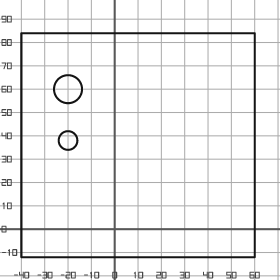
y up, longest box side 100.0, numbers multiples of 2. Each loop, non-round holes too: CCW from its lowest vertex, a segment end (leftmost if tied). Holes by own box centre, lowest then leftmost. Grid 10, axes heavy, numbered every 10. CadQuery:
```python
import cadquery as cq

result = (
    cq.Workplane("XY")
    .moveTo(-40.0, -12.0)
    .lineTo(60.0, -12.0)
    .lineTo(60.0, 84.0)
    .lineTo(-40.0, 84.0)
    .close()
    .moveTo(-20.0, 38.0)
    .circle(4.0)
    .moveTo(-20.0, 60.0)
    .circle(6.0)
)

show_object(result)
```